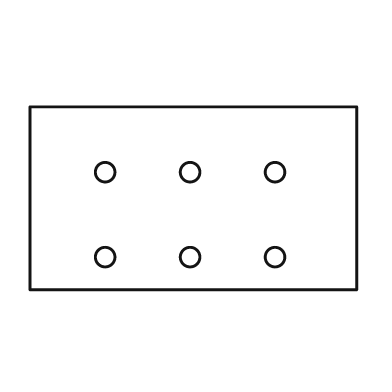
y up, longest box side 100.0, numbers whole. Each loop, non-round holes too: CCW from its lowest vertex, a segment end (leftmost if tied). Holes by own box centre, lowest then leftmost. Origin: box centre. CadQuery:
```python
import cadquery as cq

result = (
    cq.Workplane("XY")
    .moveTo(-50.0, -28.0)
    .lineTo(50.0, -28.0)
    .lineTo(50.0, 28.0)
    .lineTo(-50.0, 28.0)
    .close()
    .moveTo(-27.0, -18.0)
    .circle(3.0)
    .moveTo(-1.0, -18.0)
    .circle(3.0)
    .moveTo(25.0, -18.0)
    .circle(3.0)
    .moveTo(-27.0, 8.0)
    .circle(3.0)
    .moveTo(-1.0, 8.0)
    .circle(3.0)
    .moveTo(25.0, 8.0)
    .circle(3.0)
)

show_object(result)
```